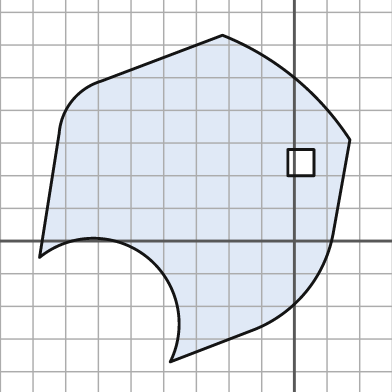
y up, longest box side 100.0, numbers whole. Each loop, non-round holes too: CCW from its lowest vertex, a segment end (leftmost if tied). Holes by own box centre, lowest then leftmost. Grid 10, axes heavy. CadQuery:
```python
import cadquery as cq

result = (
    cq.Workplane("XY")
    .moveTo(-38.0, -37.0)
    .lineTo(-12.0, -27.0)
    .threePointArc((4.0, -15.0), (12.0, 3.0))
    .lineTo(17.0, 31.0)
    .threePointArc((0.0, 50.0), (-22.0, 63.0))
    .lineTo(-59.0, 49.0)
    .threePointArc((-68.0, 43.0), (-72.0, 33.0))
    .lineTo(-78.0, -5.0)
    .threePointArc((-45.0, -5.0), (-38.0, -37.0))
    .close()
    .moveTo(-2.0, 20.0)
    .lineTo(6.0, 20.0)
    .lineTo(6.0, 28.0)
    .lineTo(-2.0, 28.0)
    .close()
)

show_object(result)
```